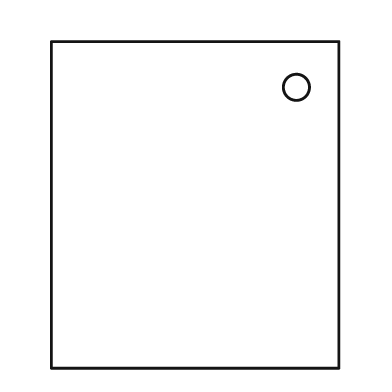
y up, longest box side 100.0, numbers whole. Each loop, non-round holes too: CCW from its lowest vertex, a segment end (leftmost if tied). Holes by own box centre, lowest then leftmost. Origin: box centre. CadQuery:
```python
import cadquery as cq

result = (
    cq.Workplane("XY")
    .moveTo(-44.0, -50.0)
    .lineTo(44.0, -50.0)
    .lineTo(44.0, 50.0)
    .lineTo(-44.0, 50.0)
    .close()
    .moveTo(31.0, 36.0)
    .circle(4.0)
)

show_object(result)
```